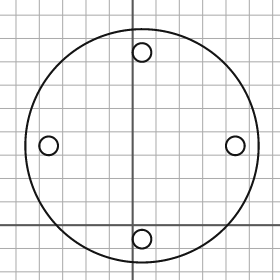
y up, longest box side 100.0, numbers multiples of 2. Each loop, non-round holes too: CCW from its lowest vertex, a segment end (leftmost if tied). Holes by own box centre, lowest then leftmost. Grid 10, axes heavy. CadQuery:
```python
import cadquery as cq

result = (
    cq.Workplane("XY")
    .moveTo(4.0, 34.0)
    .circle(50.0)
    .moveTo(4.0, -6.0)
    .circle(4.0)
    .moveTo(-36.0, 34.0)
    .circle(4.0)
    .moveTo(44.0, 34.0)
    .circle(4.0)
    .moveTo(4.0, 74.0)
    .circle(4.0)
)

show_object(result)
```